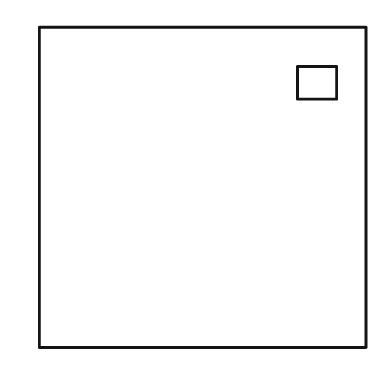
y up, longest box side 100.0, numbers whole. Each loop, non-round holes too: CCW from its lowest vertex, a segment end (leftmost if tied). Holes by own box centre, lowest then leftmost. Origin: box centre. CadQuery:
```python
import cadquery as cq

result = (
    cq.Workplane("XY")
    .moveTo(-50.0, -49.0)
    .lineTo(50.0, -49.0)
    .lineTo(50.0, 49.0)
    .lineTo(-50.0, 49.0)
    .close()
    .moveTo(29.0, 27.0)
    .lineTo(41.0, 27.0)
    .lineTo(41.0, 37.0)
    .lineTo(29.0, 37.0)
    .close()
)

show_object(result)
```